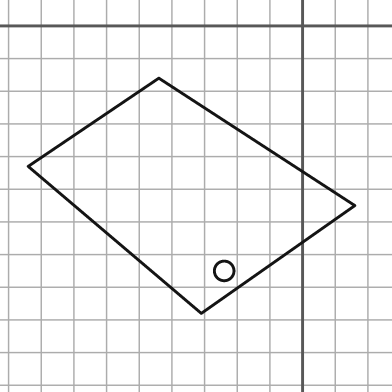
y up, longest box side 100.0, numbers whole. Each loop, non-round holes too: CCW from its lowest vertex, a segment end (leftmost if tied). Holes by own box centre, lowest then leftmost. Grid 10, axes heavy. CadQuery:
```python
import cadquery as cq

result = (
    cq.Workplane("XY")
    .moveTo(-31.0, -88.0)
    .lineTo(16.0, -55.0)
    .lineTo(-44.0, -16.0)
    .lineTo(-84.0, -43.0)
    .close()
    .moveTo(-24.0, -75.0)
    .circle(3.0)
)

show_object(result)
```